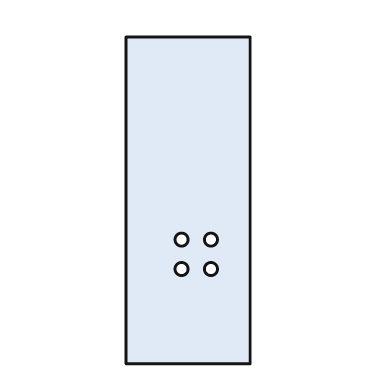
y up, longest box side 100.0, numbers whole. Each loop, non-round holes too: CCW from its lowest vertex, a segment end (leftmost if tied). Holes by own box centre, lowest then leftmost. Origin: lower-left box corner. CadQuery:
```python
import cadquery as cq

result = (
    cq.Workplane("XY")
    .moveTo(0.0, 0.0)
    .lineTo(38.0, 0.0)
    .lineTo(38.0, 100.0)
    .lineTo(0.0, 100.0)
    .close()
    .moveTo(17.0, 29.0)
    .circle(2.0)
    .moveTo(26.0, 29.0)
    .circle(2.0)
    .moveTo(17.0, 38.0)
    .circle(2.0)
    .moveTo(26.0, 38.0)
    .circle(2.0)
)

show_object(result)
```